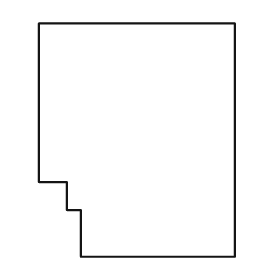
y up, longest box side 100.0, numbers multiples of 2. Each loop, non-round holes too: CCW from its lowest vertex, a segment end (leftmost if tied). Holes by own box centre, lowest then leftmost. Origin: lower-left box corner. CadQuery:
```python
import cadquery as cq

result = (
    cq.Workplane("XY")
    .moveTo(18.0, 0.0)
    .lineTo(84.0, 0.0)
    .lineTo(84.0, 100.0)
    .lineTo(0.0, 100.0)
    .lineTo(0.0, 32.0)
    .lineTo(12.0, 32.0)
    .lineTo(12.0, 20.0)
    .lineTo(18.0, 20.0)
    .close()
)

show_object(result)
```